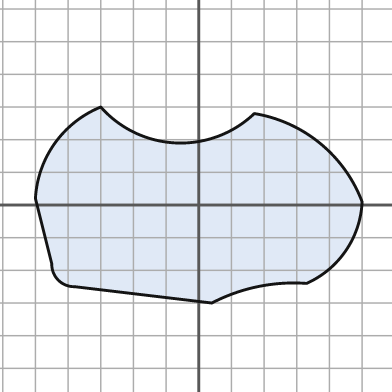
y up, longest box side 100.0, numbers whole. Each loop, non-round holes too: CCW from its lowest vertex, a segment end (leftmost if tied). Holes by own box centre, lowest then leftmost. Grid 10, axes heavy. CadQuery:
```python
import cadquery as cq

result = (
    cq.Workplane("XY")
    .moveTo(4.0, -30.0)
    .threePointArc((18.0, -25.0), (33.0, -24.0))
    .threePointArc((45.0, -14.0), (50.0, 1.0))
    .threePointArc((37.0, 19.0), (17.0, 28.0))
    .threePointArc((-7.0, 19.0), (-30.0, 30.0))
    .threePointArc((-44.0, 19.0), (-50.0, 2.0))
    .lineTo(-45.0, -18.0)
    .threePointArc((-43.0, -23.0), (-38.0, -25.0))
    .close()
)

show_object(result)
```